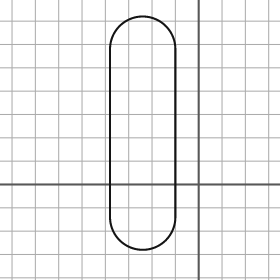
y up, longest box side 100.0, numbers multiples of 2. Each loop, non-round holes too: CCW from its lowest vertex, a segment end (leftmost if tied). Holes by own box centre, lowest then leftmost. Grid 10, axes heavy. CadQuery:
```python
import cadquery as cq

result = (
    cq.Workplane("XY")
    .moveTo(-38.0, -14.0)
    .threePointArc((-24.0, -28.0), (-10.0, -14.0))
    .lineTo(-10.0, 58.0)
    .threePointArc((-24.0, 72.0), (-38.0, 58.0))
    .close()
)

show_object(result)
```